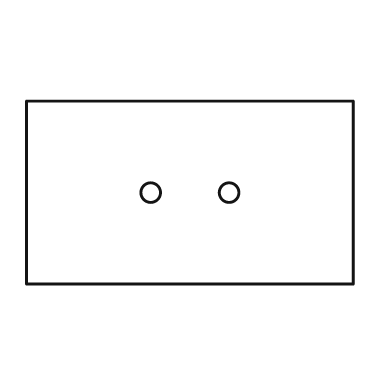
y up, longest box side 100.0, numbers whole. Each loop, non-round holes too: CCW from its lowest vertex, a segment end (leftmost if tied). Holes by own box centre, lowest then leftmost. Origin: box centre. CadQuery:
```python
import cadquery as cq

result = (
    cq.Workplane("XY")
    .moveTo(-50.0, -28.0)
    .lineTo(50.0, -28.0)
    .lineTo(50.0, 28.0)
    .lineTo(-50.0, 28.0)
    .close()
    .moveTo(-12.0, 0.0)
    .circle(3.0)
    .moveTo(12.0, 0.0)
    .circle(3.0)
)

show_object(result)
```